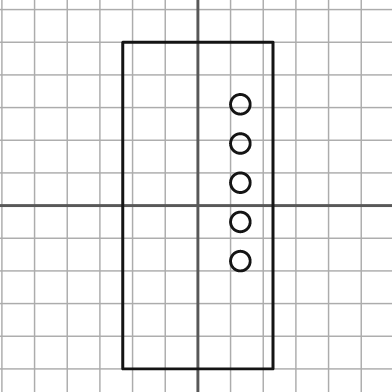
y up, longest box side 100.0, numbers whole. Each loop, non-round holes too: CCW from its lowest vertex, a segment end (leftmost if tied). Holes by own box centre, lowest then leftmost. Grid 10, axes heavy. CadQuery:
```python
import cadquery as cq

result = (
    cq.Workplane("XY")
    .moveTo(-23.0, -50.0)
    .lineTo(23.0, -50.0)
    .lineTo(23.0, 50.0)
    .lineTo(-23.0, 50.0)
    .close()
    .moveTo(13.0, -17.0)
    .circle(3.0)
    .moveTo(13.0, -5.0)
    .circle(3.0)
    .moveTo(13.0, 7.0)
    .circle(3.0)
    .moveTo(13.0, 19.0)
    .circle(3.0)
    .moveTo(13.0, 31.0)
    .circle(3.0)
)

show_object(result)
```